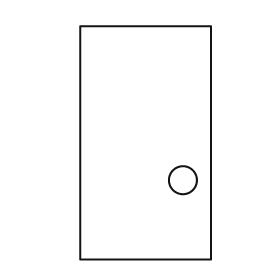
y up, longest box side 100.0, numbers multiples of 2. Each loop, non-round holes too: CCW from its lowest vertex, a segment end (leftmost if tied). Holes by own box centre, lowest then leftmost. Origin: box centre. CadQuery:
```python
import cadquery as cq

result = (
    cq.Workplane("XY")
    .moveTo(-28.0, -50.0)
    .lineTo(28.0, -50.0)
    .lineTo(28.0, 50.0)
    .lineTo(-28.0, 50.0)
    .close()
    .moveTo(16.0, -16.0)
    .circle(6.0)
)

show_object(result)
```